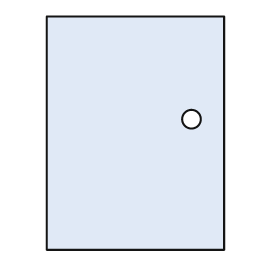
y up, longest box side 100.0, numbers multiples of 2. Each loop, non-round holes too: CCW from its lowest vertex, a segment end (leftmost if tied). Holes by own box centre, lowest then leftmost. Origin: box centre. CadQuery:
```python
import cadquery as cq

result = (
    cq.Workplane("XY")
    .moveTo(-38.0, -50.0)
    .lineTo(38.0, -50.0)
    .lineTo(38.0, 50.0)
    .lineTo(-38.0, 50.0)
    .close()
    .moveTo(24.0, 6.0)
    .circle(4.0)
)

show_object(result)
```